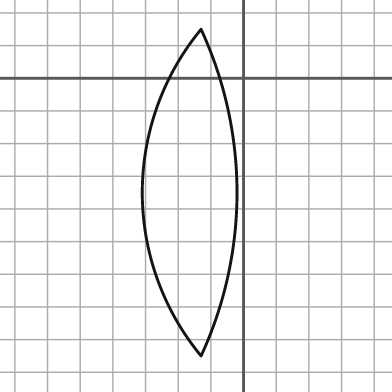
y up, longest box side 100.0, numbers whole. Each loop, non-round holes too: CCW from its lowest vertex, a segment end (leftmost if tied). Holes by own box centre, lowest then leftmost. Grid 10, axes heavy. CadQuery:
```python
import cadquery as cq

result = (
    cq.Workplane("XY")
    .moveTo(-13.0, -85.0)
    .threePointArc((-2.0, -35.0), (-13.0, 15.0))
    .threePointArc((-31.0, -35.0), (-13.0, -85.0))
    .close()
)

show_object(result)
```